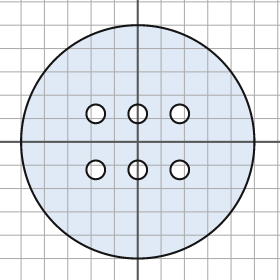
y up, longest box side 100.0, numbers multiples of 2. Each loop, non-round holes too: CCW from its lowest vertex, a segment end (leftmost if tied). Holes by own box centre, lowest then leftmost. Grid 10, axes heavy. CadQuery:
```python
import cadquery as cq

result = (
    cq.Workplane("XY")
    .moveTo(0.0, 0.0)
    .circle(50.0)
    .moveTo(-18.0, -12.0)
    .circle(4.0)
    .moveTo(0.0, -12.0)
    .circle(4.0)
    .moveTo(18.0, -12.0)
    .circle(4.0)
    .moveTo(-18.0, 12.0)
    .circle(4.0)
    .moveTo(0.0, 12.0)
    .circle(4.0)
    .moveTo(18.0, 12.0)
    .circle(4.0)
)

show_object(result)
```